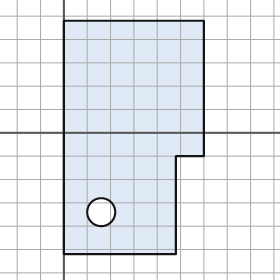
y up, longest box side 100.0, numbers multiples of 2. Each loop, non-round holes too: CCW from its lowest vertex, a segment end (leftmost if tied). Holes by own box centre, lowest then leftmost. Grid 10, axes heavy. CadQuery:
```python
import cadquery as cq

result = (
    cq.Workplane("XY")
    .moveTo(0.0, -52.0)
    .lineTo(48.0, -52.0)
    .lineTo(48.0, -10.0)
    .lineTo(60.0, -10.0)
    .lineTo(60.0, 48.0)
    .lineTo(0.0, 48.0)
    .close()
    .moveTo(16.0, -34.0)
    .circle(6.0)
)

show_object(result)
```